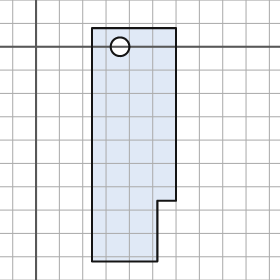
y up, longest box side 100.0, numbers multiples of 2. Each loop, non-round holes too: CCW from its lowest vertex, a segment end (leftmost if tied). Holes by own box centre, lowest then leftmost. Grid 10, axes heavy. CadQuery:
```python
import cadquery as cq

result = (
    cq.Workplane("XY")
    .moveTo(24.0, -92.0)
    .lineTo(52.0, -92.0)
    .lineTo(52.0, -66.0)
    .lineTo(60.0, -66.0)
    .lineTo(60.0, 8.0)
    .lineTo(24.0, 8.0)
    .close()
    .moveTo(36.0, 0.0)
    .circle(4.0)
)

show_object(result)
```